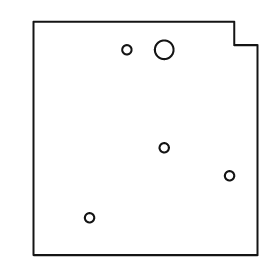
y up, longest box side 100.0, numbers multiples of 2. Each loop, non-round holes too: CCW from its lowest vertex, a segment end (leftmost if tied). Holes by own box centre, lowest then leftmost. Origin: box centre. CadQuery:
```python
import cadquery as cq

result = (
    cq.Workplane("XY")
    .moveTo(-48.0, -50.0)
    .lineTo(48.0, -50.0)
    .lineTo(48.0, 40.0)
    .lineTo(38.0, 40.0)
    .lineTo(38.0, 50.0)
    .lineTo(-48.0, 50.0)
    .close()
    .moveTo(-24.0, -34.0)
    .circle(2.0)
    .moveTo(36.0, -16.0)
    .circle(2.0)
    .moveTo(8.0, -4.0)
    .circle(2.0)
    .moveTo(-8.0, 38.0)
    .circle(2.0)
    .moveTo(8.0, 38.0)
    .circle(4.0)
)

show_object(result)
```